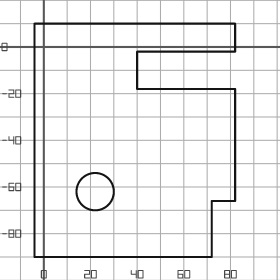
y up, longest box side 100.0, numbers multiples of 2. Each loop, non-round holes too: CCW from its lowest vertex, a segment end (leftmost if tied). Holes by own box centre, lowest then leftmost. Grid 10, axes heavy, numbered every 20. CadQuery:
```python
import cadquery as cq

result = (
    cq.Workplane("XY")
    .moveTo(-4.0, -90.0)
    .lineTo(72.0, -90.0)
    .lineTo(72.0, -66.0)
    .lineTo(82.0, -66.0)
    .lineTo(82.0, -18.0)
    .lineTo(40.0, -18.0)
    .lineTo(40.0, -2.0)
    .lineTo(82.0, -2.0)
    .lineTo(82.0, 10.0)
    .lineTo(-4.0, 10.0)
    .close()
    .moveTo(22.0, -62.0)
    .circle(8.0)
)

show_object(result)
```